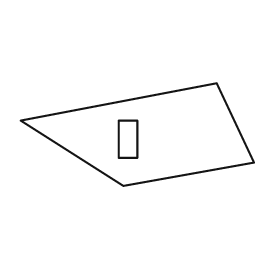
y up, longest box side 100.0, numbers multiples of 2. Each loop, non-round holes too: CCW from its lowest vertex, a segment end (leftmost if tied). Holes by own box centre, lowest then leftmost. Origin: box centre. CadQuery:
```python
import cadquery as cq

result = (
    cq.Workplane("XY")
    .moveTo(-6.0, -22.0)
    .lineTo(50.0, -12.0)
    .lineTo(34.0, 22.0)
    .lineTo(-50.0, 6.0)
    .close()
    .moveTo(-8.0, -10.0)
    .lineTo(0.0, -10.0)
    .lineTo(0.0, 6.0)
    .lineTo(-8.0, 6.0)
    .close()
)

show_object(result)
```